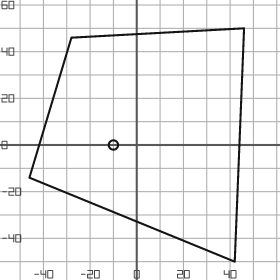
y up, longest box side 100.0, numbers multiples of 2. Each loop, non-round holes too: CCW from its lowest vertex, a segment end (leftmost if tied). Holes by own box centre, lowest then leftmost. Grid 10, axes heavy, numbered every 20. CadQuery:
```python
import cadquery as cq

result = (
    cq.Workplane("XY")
    .moveTo(42.0, -50.0)
    .lineTo(46.0, 50.0)
    .lineTo(-28.0, 46.0)
    .lineTo(-46.0, -14.0)
    .close()
    .moveTo(-10.0, 0.0)
    .circle(2.0)
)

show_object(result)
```